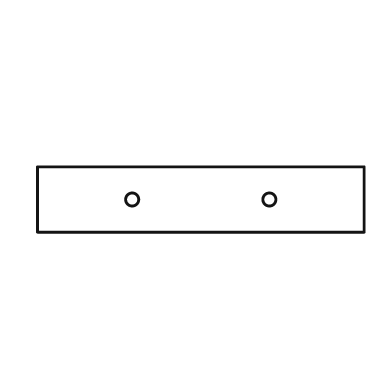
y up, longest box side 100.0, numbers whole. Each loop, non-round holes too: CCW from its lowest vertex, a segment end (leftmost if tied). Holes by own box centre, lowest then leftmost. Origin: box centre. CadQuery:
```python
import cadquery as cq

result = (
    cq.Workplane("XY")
    .moveTo(-50.0, -10.0)
    .lineTo(50.0, -10.0)
    .lineTo(50.0, 10.0)
    .lineTo(-50.0, 10.0)
    .close()
    .moveTo(-21.0, 0.0)
    .circle(2.0)
    .moveTo(21.0, 0.0)
    .circle(2.0)
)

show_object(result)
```